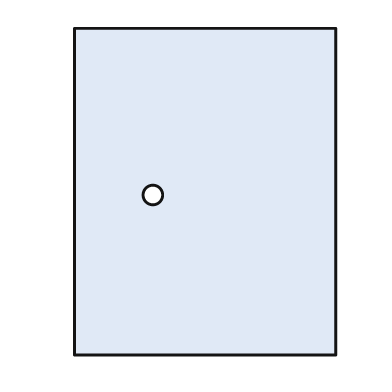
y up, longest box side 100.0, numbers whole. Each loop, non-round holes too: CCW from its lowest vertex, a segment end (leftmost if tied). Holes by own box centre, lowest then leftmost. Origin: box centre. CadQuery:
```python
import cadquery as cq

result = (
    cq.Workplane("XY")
    .moveTo(-40.0, -50.0)
    .lineTo(40.0, -50.0)
    .lineTo(40.0, 50.0)
    .lineTo(-40.0, 50.0)
    .close()
    .moveTo(-16.0, -1.0)
    .circle(3.0)
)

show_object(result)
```